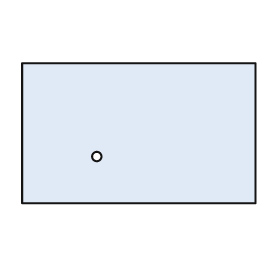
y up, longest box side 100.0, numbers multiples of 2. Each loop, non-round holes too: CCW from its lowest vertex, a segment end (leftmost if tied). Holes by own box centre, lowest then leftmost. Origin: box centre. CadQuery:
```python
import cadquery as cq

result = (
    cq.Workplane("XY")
    .moveTo(-50.0, -30.0)
    .lineTo(50.0, -30.0)
    .lineTo(50.0, 30.0)
    .lineTo(-50.0, 30.0)
    .close()
    .moveTo(-18.0, -10.0)
    .circle(2.0)
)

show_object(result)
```